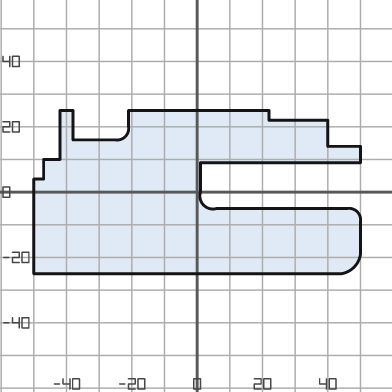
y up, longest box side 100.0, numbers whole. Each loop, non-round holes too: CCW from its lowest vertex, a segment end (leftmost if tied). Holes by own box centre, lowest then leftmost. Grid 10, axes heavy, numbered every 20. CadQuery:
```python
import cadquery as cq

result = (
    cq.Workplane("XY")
    .moveTo(-50.0, -25.0)
    .lineTo(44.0, -25.0)
    .threePointArc((48.0, -23.0), (50.0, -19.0))
    .lineTo(50.0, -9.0)
    .threePointArc((49.0, -6.0), (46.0, -5.0))
    .lineTo(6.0, -5.0)
    .threePointArc((2.0, -4.0), (1.0, 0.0))
    .lineTo(1.0, 9.0)
    .lineTo(50.0, 9.0)
    .lineTo(50.0, 14.0)
    .lineTo(40.0, 14.0)
    .lineTo(40.0, 22.0)
    .lineTo(22.0, 22.0)
    .lineTo(22.0, 25.0)
    .lineTo(-21.0, 25.0)
    .lineTo(-21.0, 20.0)
    .threePointArc((-22.0, 17.0), (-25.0, 16.0))
    .lineTo(-38.0, 16.0)
    .lineTo(-38.0, 25.0)
    .lineTo(-42.0, 25.0)
    .lineTo(-42.0, 10.0)
    .lineTo(-47.0, 10.0)
    .lineTo(-47.0, 4.0)
    .lineTo(-50.0, 4.0)
    .close()
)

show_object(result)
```